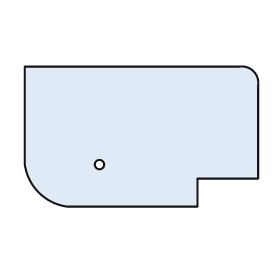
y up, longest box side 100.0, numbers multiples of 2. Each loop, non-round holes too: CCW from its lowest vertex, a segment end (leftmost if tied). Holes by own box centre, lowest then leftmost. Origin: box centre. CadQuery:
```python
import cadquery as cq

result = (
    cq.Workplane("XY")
    .moveTo(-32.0, -30.0)
    .lineTo(24.0, -30.0)
    .lineTo(24.0, -18.0)
    .lineTo(50.0, -18.0)
    .lineTo(50.0, 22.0)
    .threePointArc((48.0, 28.0), (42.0, 30.0))
    .lineTo(-50.0, 30.0)
    .lineTo(-50.0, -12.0)
    .threePointArc((-44.0, -24.0), (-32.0, -30.0))
    .close()
    .moveTo(-18.0, -12.0)
    .circle(2.0)
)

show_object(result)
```